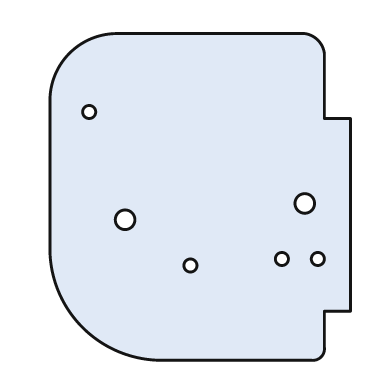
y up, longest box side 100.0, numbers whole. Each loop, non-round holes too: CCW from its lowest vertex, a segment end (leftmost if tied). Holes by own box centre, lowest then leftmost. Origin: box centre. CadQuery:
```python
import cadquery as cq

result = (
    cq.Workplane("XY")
    .moveTo(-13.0, -50.0)
    .lineTo(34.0, -50.0)
    .threePointArc((37.0, -49.0), (38.0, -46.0))
    .lineTo(38.0, -35.0)
    .lineTo(46.0, -35.0)
    .lineTo(46.0, 24.0)
    .lineTo(38.0, 24.0)
    .lineTo(38.0, 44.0)
    .threePointArc((36.0, 48.0), (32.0, 50.0))
    .lineTo(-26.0, 50.0)
    .threePointArc((-40.0, 44.0), (-46.0, 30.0))
    .lineTo(-46.0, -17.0)
    .threePointArc((-36.0, -40.0), (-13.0, -50.0))
    .close()
    .moveTo(-3.0, -21.0)
    .circle(2.0)
    .moveTo(25.0, -19.0)
    .circle(2.0)
    .moveTo(36.0, -19.0)
    .circle(2.0)
    .moveTo(-23.0, -7.0)
    .circle(3.0)
    .moveTo(32.0, -2.0)
    .circle(3.0)
    .moveTo(-34.0, 26.0)
    .circle(2.0)
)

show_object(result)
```